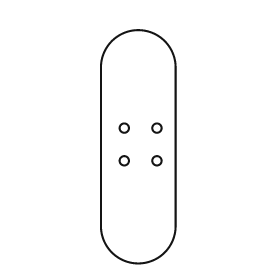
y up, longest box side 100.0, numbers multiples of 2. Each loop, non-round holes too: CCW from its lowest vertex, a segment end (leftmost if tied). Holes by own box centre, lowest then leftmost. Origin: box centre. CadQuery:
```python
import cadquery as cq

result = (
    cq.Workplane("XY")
    .moveTo(-16.0, -34.0)
    .threePointArc((0.0, -50.0), (16.0, -34.0))
    .lineTo(16.0, 34.0)
    .threePointArc((0.0, 50.0), (-16.0, 34.0))
    .close()
    .moveTo(-6.0, -6.0)
    .circle(2.0)
    .moveTo(8.0, -6.0)
    .circle(2.0)
    .moveTo(-6.0, 8.0)
    .circle(2.0)
    .moveTo(8.0, 8.0)
    .circle(2.0)
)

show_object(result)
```